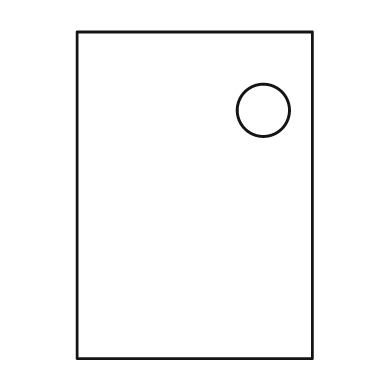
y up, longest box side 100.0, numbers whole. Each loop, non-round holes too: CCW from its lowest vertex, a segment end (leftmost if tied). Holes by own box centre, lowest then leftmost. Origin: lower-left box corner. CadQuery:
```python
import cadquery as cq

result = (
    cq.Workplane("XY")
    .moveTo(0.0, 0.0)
    .lineTo(72.0, 0.0)
    .lineTo(72.0, 100.0)
    .lineTo(0.0, 100.0)
    .close()
    .moveTo(57.0, 76.0)
    .circle(8.0)
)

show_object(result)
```